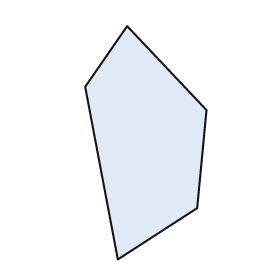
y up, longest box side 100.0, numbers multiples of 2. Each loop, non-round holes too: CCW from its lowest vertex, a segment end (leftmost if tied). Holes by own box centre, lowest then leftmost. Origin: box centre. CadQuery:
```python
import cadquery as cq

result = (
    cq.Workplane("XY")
    .moveTo(-12.0, -50.0)
    .lineTo(22.0, -28.0)
    .lineTo(26.0, 14.0)
    .lineTo(-8.0, 50.0)
    .lineTo(-26.0, 24.0)
    .close()
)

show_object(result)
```